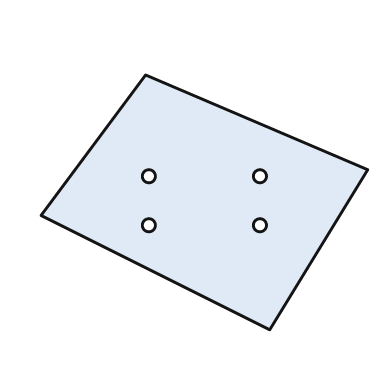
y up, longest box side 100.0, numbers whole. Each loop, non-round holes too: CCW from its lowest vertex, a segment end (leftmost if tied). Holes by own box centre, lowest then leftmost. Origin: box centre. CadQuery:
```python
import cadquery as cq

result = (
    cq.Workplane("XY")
    .moveTo(20.0, -39.0)
    .lineTo(50.0, 10.0)
    .lineTo(-18.0, 39.0)
    .lineTo(-50.0, -4.0)
    .close()
    .moveTo(-17.0, -7.0)
    .circle(2.0)
    .moveTo(17.0, -7.0)
    .circle(2.0)
    .moveTo(-17.0, 8.0)
    .circle(2.0)
    .moveTo(17.0, 8.0)
    .circle(2.0)
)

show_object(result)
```